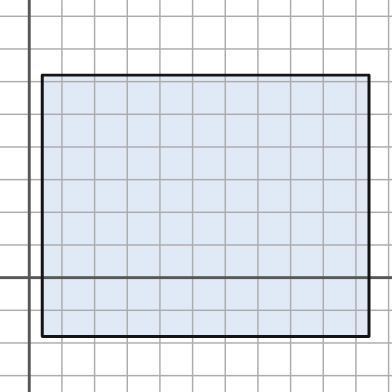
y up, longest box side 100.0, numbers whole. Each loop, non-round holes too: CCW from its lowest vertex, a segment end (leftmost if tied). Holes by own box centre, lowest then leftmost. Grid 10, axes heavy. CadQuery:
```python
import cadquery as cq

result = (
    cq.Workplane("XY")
    .moveTo(4.0, -18.0)
    .lineTo(104.0, -18.0)
    .lineTo(104.0, 62.0)
    .lineTo(4.0, 62.0)
    .close()
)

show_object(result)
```